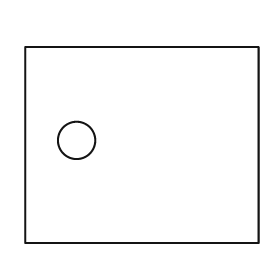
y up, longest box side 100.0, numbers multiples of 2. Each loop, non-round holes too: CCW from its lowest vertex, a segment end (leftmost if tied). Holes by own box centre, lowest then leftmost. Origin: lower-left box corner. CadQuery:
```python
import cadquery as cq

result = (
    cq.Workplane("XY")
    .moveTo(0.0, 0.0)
    .lineTo(100.0, 0.0)
    .lineTo(100.0, 84.0)
    .lineTo(0.0, 84.0)
    .close()
    .moveTo(22.0, 44.0)
    .circle(8.0)
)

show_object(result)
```